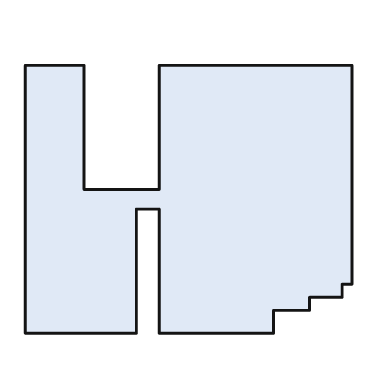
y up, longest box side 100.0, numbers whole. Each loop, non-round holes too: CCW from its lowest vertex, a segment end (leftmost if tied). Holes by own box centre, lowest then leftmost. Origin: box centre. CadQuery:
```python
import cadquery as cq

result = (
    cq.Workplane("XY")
    .moveTo(-50.0, -41.0)
    .lineTo(-16.0, -41.0)
    .lineTo(-16.0, -3.0)
    .lineTo(-9.0, -3.0)
    .lineTo(-9.0, -41.0)
    .lineTo(26.0, -41.0)
    .lineTo(26.0, -34.0)
    .lineTo(37.0, -34.0)
    .lineTo(37.0, -30.0)
    .lineTo(47.0, -30.0)
    .lineTo(47.0, -26.0)
    .lineTo(50.0, -26.0)
    .lineTo(50.0, 41.0)
    .lineTo(-9.0, 41.0)
    .lineTo(-9.0, 3.0)
    .lineTo(-32.0, 3.0)
    .lineTo(-32.0, 41.0)
    .lineTo(-50.0, 41.0)
    .close()
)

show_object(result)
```